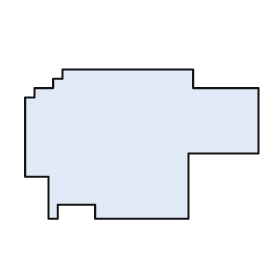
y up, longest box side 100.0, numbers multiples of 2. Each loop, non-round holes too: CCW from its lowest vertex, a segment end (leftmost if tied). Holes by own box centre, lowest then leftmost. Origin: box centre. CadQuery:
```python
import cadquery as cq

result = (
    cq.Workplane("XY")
    .moveTo(-40.0, -32.0)
    .lineTo(-36.0, -32.0)
    .lineTo(-36.0, -26.0)
    .lineTo(-20.0, -26.0)
    .lineTo(-20.0, -32.0)
    .lineTo(20.0, -32.0)
    .lineTo(20.0, -4.0)
    .lineTo(50.0, -4.0)
    .lineTo(50.0, 24.0)
    .lineTo(22.0, 24.0)
    .lineTo(22.0, 32.0)
    .lineTo(-34.0, 32.0)
    .lineTo(-34.0, 28.0)
    .lineTo(-38.0, 28.0)
    .lineTo(-38.0, 24.0)
    .lineTo(-46.0, 24.0)
    .lineTo(-46.0, 20.0)
    .lineTo(-50.0, 20.0)
    .lineTo(-50.0, -14.0)
    .lineTo(-40.0, -14.0)
    .close()
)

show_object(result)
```